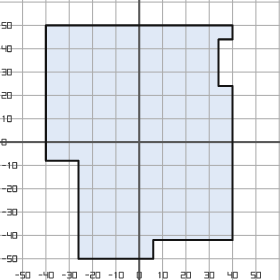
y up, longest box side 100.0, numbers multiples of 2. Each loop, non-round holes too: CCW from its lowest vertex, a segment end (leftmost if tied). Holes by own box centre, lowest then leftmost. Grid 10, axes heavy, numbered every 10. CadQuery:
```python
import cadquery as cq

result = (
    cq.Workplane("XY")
    .moveTo(-26.0, -50.0)
    .lineTo(6.0, -50.0)
    .lineTo(6.0, -42.0)
    .lineTo(40.0, -42.0)
    .lineTo(40.0, 24.0)
    .lineTo(34.0, 24.0)
    .lineTo(34.0, 44.0)
    .lineTo(40.0, 44.0)
    .lineTo(40.0, 50.0)
    .lineTo(-40.0, 50.0)
    .lineTo(-40.0, -8.0)
    .lineTo(-26.0, -8.0)
    .close()
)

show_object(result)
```